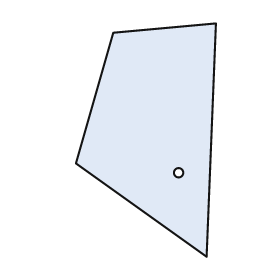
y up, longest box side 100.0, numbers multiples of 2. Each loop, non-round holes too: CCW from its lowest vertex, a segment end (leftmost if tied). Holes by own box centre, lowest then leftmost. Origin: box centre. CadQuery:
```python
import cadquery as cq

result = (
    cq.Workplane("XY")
    .moveTo(26.0, -50.0)
    .lineTo(30.0, 50.0)
    .lineTo(-14.0, 46.0)
    .lineTo(-30.0, -10.0)
    .close()
    .moveTo(14.0, -14.0)
    .circle(2.0)
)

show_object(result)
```